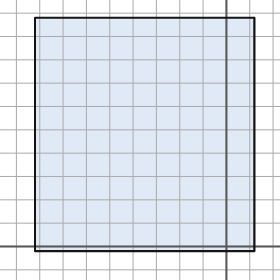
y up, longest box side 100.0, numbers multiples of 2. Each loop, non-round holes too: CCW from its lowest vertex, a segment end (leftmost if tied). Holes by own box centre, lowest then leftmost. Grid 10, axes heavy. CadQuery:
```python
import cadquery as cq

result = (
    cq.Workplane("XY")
    .moveTo(-82.0, -2.0)
    .lineTo(12.0, -2.0)
    .lineTo(12.0, 98.0)
    .lineTo(-82.0, 98.0)
    .close()
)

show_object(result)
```